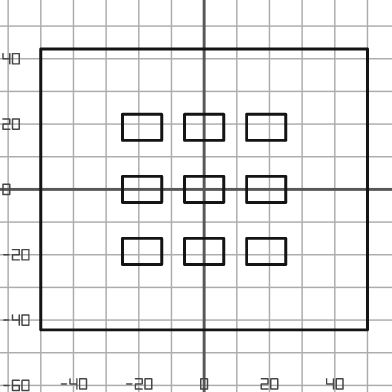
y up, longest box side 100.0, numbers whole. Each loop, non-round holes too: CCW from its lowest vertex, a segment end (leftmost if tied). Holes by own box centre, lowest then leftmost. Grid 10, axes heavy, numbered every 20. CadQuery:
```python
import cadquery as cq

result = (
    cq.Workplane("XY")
    .moveTo(-50.0, -43.0)
    .lineTo(50.0, -43.0)
    .lineTo(50.0, 43.0)
    .lineTo(-50.0, 43.0)
    .close()
    .moveTo(-25.0, -23.0)
    .lineTo(-13.0, -23.0)
    .lineTo(-13.0, -15.0)
    .lineTo(-25.0, -15.0)
    .close()
    .moveTo(-6.0, -23.0)
    .lineTo(6.0, -23.0)
    .lineTo(6.0, -15.0)
    .lineTo(-6.0, -15.0)
    .close()
    .moveTo(13.0, -23.0)
    .lineTo(25.0, -23.0)
    .lineTo(25.0, -15.0)
    .lineTo(13.0, -15.0)
    .close()
    .moveTo(-25.0, -4.0)
    .lineTo(-13.0, -4.0)
    .lineTo(-13.0, 4.0)
    .lineTo(-25.0, 4.0)
    .close()
    .moveTo(-6.0, -4.0)
    .lineTo(6.0, -4.0)
    .lineTo(6.0, 4.0)
    .lineTo(-6.0, 4.0)
    .close()
    .moveTo(13.0, -4.0)
    .lineTo(25.0, -4.0)
    .lineTo(25.0, 4.0)
    .lineTo(13.0, 4.0)
    .close()
    .moveTo(-25.0, 15.0)
    .lineTo(-13.0, 15.0)
    .lineTo(-13.0, 23.0)
    .lineTo(-25.0, 23.0)
    .close()
    .moveTo(-6.0, 15.0)
    .lineTo(6.0, 15.0)
    .lineTo(6.0, 23.0)
    .lineTo(-6.0, 23.0)
    .close()
    .moveTo(13.0, 15.0)
    .lineTo(25.0, 15.0)
    .lineTo(25.0, 23.0)
    .lineTo(13.0, 23.0)
    .close()
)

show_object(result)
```